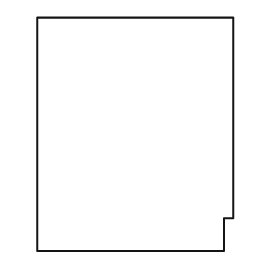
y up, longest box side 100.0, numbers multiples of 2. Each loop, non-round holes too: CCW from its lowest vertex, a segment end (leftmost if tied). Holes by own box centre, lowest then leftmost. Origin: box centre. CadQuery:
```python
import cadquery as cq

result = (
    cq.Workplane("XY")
    .moveTo(-42.0, -50.0)
    .lineTo(38.0, -50.0)
    .lineTo(38.0, -36.0)
    .lineTo(42.0, -36.0)
    .lineTo(42.0, 50.0)
    .lineTo(-42.0, 50.0)
    .close()
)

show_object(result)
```